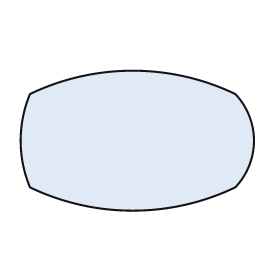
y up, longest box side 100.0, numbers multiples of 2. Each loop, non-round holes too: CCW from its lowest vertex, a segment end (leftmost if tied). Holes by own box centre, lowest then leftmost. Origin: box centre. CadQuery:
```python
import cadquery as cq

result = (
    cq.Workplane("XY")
    .moveTo(-46.0, -20.0)
    .threePointArc((-2.0, -30.0), (42.0, -20.0))
    .threePointArc((50.0, 0.0), (42.0, 20.0))
    .threePointArc((-2.0, 30.0), (-46.0, 20.0))
    .threePointArc((-50.0, 0.0), (-46.0, -20.0))
    .close()
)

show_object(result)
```